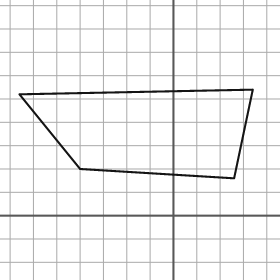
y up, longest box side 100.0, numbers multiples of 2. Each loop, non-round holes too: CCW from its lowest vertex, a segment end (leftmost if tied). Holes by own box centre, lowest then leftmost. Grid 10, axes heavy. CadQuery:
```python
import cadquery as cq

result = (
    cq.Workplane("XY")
    .moveTo(26.0, 16.0)
    .lineTo(34.0, 54.0)
    .lineTo(-66.0, 52.0)
    .lineTo(-40.0, 20.0)
    .close()
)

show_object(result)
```